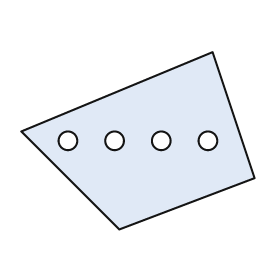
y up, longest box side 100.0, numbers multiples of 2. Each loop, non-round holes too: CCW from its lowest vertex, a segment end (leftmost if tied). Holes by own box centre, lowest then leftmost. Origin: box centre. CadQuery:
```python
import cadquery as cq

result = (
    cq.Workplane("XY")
    .moveTo(-8.0, -38.0)
    .lineTo(50.0, -16.0)
    .lineTo(32.0, 38.0)
    .lineTo(-50.0, 4.0)
    .close()
    .moveTo(-30.0, 0.0)
    .circle(4.0)
    .moveTo(-10.0, 0.0)
    .circle(4.0)
    .moveTo(10.0, 0.0)
    .circle(4.0)
    .moveTo(30.0, 0.0)
    .circle(4.0)
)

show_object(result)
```